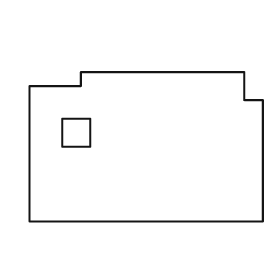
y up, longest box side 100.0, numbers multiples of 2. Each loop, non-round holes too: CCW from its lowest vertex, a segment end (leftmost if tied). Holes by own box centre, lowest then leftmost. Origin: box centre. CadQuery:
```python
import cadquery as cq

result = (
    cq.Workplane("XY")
    .moveTo(-50.0, -32.0)
    .lineTo(50.0, -32.0)
    .lineTo(50.0, 20.0)
    .lineTo(42.0, 20.0)
    .lineTo(42.0, 32.0)
    .lineTo(-28.0, 32.0)
    .lineTo(-28.0, 26.0)
    .lineTo(-50.0, 26.0)
    .close()
    .moveTo(-36.0, 0.0)
    .lineTo(-24.0, 0.0)
    .lineTo(-24.0, 12.0)
    .lineTo(-36.0, 12.0)
    .close()
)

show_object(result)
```